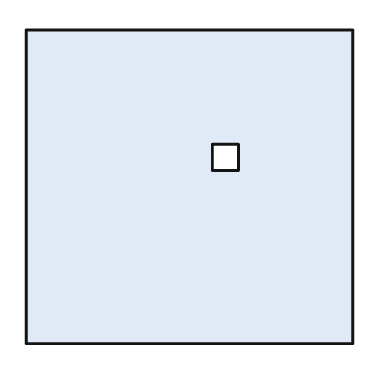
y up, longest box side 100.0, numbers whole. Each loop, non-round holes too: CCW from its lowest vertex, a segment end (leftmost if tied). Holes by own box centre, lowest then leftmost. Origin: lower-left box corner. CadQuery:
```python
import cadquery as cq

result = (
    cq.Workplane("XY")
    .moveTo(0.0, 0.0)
    .lineTo(100.0, 0.0)
    .lineTo(100.0, 96.0)
    .lineTo(0.0, 96.0)
    .close()
    .moveTo(57.0, 53.0)
    .lineTo(65.0, 53.0)
    .lineTo(65.0, 61.0)
    .lineTo(57.0, 61.0)
    .close()
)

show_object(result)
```